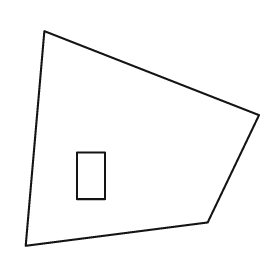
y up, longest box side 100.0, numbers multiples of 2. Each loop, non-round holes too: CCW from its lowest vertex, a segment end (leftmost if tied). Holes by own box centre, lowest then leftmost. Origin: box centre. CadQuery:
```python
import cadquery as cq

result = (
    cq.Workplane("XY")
    .moveTo(-50.0, -46.0)
    .lineTo(28.0, -36.0)
    .lineTo(50.0, 10.0)
    .lineTo(-42.0, 46.0)
    .close()
    .moveTo(-28.0, -26.0)
    .lineTo(-16.0, -26.0)
    .lineTo(-16.0, -6.0)
    .lineTo(-28.0, -6.0)
    .close()
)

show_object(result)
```